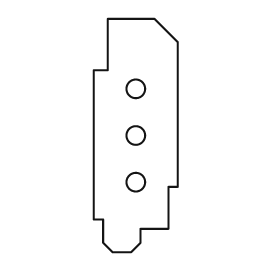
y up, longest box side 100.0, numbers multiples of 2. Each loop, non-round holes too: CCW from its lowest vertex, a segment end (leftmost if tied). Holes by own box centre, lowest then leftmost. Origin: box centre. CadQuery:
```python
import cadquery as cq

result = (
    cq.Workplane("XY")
    .moveTo(-10.0, -50.0)
    .lineTo(-2.0, -50.0)
    .lineTo(2.0, -46.0)
    .lineTo(2.0, -40.0)
    .lineTo(14.0, -40.0)
    .lineTo(14.0, -22.0)
    .lineTo(18.0, -22.0)
    .lineTo(18.0, 40.0)
    .lineTo(8.0, 50.0)
    .lineTo(-12.0, 50.0)
    .lineTo(-12.0, 28.0)
    .lineTo(-18.0, 28.0)
    .lineTo(-18.0, -36.0)
    .lineTo(-14.0, -36.0)
    .lineTo(-14.0, -46.0)
    .close()
    .moveTo(0.0, -20.0)
    .circle(4.0)
    .moveTo(0.0, 0.0)
    .circle(4.0)
    .moveTo(0.0, 20.0)
    .circle(4.0)
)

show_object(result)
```